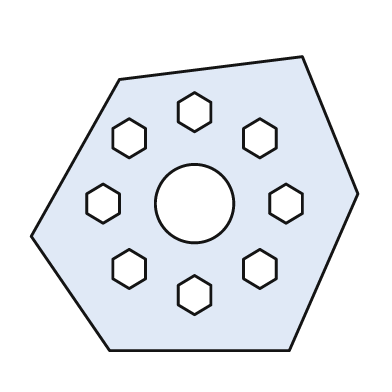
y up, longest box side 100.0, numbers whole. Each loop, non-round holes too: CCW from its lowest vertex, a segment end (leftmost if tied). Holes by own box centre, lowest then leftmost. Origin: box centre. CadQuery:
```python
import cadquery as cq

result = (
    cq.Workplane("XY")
    .moveTo(-26.0, -45.0)
    .lineTo(29.0, -45.0)
    .lineTo(50.0, 3.0)
    .lineTo(33.0, 45.0)
    .lineTo(-23.0, 38.0)
    .lineTo(-50.0, -10.0)
    .close()
    .moveTo(0.0, -34.0)
    .lineTo(5.0, -31.0)
    .lineTo(5.0, -25.0)
    .lineTo(0.0, -22.0)
    .lineTo(-5.0, -25.0)
    .lineTo(-5.0, -31.0)
    .close()
    .moveTo(-20.0, -26.0)
    .lineTo(-15.0, -23.0)
    .lineTo(-15.0, -17.0)
    .lineTo(-20.0, -14.0)
    .lineTo(-25.0, -17.0)
    .lineTo(-25.0, -23.0)
    .close()
    .moveTo(20.0, -26.0)
    .lineTo(25.0, -23.0)
    .lineTo(25.0, -17.0)
    .lineTo(20.0, -14.0)
    .lineTo(15.0, -17.0)
    .lineTo(15.0, -23.0)
    .close()
    .moveTo(-28.0, -6.0)
    .lineTo(-23.0, -3.0)
    .lineTo(-23.0, 3.0)
    .lineTo(-28.0, 6.0)
    .lineTo(-33.0, 3.0)
    .lineTo(-33.0, -3.0)
    .close()
    .moveTo(0.0, 0.0)
    .circle(12.0)
    .moveTo(28.0, -6.0)
    .lineTo(33.0, -3.0)
    .lineTo(33.0, 3.0)
    .lineTo(28.0, 6.0)
    .lineTo(23.0, 3.0)
    .lineTo(23.0, -3.0)
    .close()
    .moveTo(-20.0, 14.0)
    .lineTo(-15.0, 17.0)
    .lineTo(-15.0, 23.0)
    .lineTo(-20.0, 26.0)
    .lineTo(-25.0, 23.0)
    .lineTo(-25.0, 17.0)
    .close()
    .moveTo(20.0, 14.0)
    .lineTo(25.0, 17.0)
    .lineTo(25.0, 23.0)
    .lineTo(20.0, 26.0)
    .lineTo(15.0, 23.0)
    .lineTo(15.0, 17.0)
    .close()
    .moveTo(0.0, 22.0)
    .lineTo(5.0, 25.0)
    .lineTo(5.0, 31.0)
    .lineTo(0.0, 34.0)
    .lineTo(-5.0, 31.0)
    .lineTo(-5.0, 25.0)
    .close()
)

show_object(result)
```